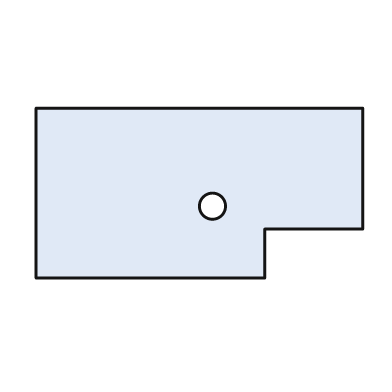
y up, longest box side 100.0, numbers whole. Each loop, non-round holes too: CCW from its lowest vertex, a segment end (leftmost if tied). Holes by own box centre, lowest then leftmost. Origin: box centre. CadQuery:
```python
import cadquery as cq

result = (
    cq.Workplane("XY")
    .moveTo(-50.0, -26.0)
    .lineTo(20.0, -26.0)
    .lineTo(20.0, -11.0)
    .lineTo(50.0, -11.0)
    .lineTo(50.0, 26.0)
    .lineTo(-50.0, 26.0)
    .close()
    .moveTo(4.0, -4.0)
    .circle(4.0)
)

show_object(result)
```